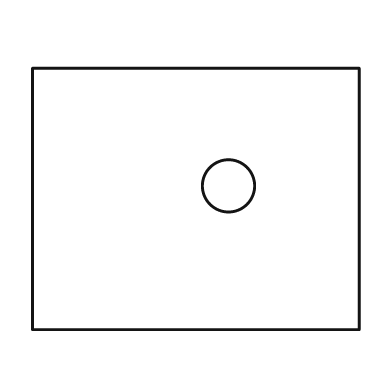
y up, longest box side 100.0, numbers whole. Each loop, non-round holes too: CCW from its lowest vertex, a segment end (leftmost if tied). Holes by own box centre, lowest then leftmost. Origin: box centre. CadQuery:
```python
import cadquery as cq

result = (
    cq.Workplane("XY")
    .moveTo(-50.0, -40.0)
    .lineTo(50.0, -40.0)
    .lineTo(50.0, 40.0)
    .lineTo(-50.0, 40.0)
    .close()
    .moveTo(10.0, 4.0)
    .circle(8.0)
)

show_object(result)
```